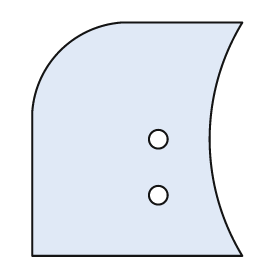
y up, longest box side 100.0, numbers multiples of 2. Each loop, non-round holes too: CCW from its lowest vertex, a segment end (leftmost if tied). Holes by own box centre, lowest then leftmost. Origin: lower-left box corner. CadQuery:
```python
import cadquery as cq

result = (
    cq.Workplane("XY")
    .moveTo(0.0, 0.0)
    .lineTo(90.0, 0.0)
    .threePointArc((76.0, 50.0), (90.0, 100.0))
    .lineTo(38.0, 100.0)
    .threePointArc((12.0, 88.0), (0.0, 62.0))
    .close()
    .moveTo(54.0, 26.0)
    .circle(4.0)
    .moveTo(54.0, 50.0)
    .circle(4.0)
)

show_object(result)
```